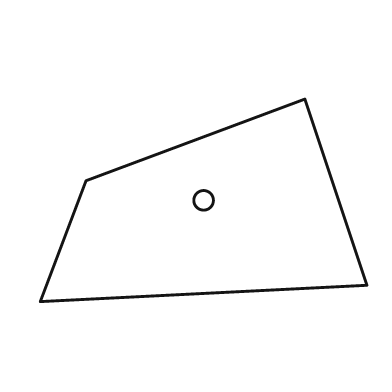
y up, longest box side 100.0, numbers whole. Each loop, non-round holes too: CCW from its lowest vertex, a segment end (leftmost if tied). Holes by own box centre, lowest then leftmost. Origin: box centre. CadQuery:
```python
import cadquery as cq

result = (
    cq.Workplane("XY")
    .moveTo(-50.0, -31.0)
    .lineTo(50.0, -26.0)
    .lineTo(31.0, 31.0)
    .lineTo(-36.0, 6.0)
    .close()
    .moveTo(0.0, 0.0)
    .circle(3.0)
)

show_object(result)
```